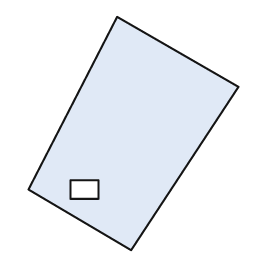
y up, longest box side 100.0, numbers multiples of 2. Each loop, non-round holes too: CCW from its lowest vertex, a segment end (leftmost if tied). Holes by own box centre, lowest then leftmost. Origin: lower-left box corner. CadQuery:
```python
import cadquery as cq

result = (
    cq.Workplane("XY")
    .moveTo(44.0, 0.0)
    .lineTo(90.0, 70.0)
    .lineTo(38.0, 100.0)
    .lineTo(0.0, 26.0)
    .close()
    .moveTo(18.0, 22.0)
    .lineTo(30.0, 22.0)
    .lineTo(30.0, 30.0)
    .lineTo(18.0, 30.0)
    .close()
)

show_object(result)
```